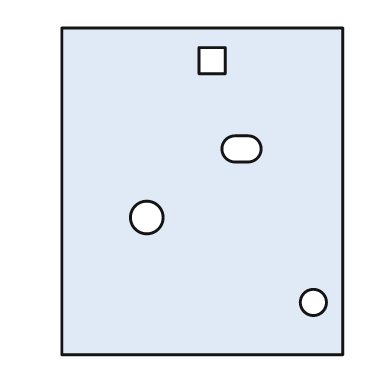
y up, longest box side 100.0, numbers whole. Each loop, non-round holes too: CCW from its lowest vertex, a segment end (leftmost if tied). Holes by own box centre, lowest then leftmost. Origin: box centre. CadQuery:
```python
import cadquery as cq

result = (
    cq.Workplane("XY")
    .moveTo(-43.0, -50.0)
    .lineTo(43.0, -50.0)
    .lineTo(43.0, 50.0)
    .lineTo(-43.0, 50.0)
    .close()
    .moveTo(34.0, -34.0)
    .circle(4.0)
    .moveTo(-17.0, -8.0)
    .circle(5.0)
    .moveTo(10.0, 9.0)
    .lineTo(14.0, 9.0)
    .threePointArc((18.0, 13.0), (14.0, 17.0))
    .lineTo(10.0, 17.0)
    .threePointArc((6.0, 13.0), (10.0, 9.0))
    .close()
    .moveTo(-1.0, 36.0)
    .lineTo(7.0, 36.0)
    .lineTo(7.0, 44.0)
    .lineTo(-1.0, 44.0)
    .close()
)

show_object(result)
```